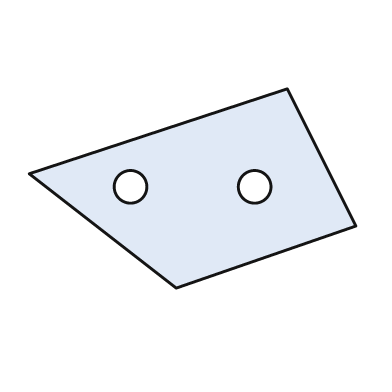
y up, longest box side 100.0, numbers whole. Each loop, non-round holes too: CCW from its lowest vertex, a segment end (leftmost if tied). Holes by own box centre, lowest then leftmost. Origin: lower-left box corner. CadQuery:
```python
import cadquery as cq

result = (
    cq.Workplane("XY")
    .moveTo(45.0, 0.0)
    .lineTo(100.0, 19.0)
    .lineTo(79.0, 61.0)
    .lineTo(0.0, 35.0)
    .close()
    .moveTo(31.0, 31.0)
    .circle(5.0)
    .moveTo(69.0, 31.0)
    .circle(5.0)
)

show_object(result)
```